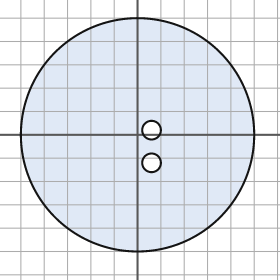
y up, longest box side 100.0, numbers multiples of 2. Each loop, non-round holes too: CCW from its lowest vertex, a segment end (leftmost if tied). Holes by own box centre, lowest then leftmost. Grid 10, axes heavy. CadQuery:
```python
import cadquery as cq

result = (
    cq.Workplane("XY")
    .moveTo(0.0, 0.0)
    .circle(50.0)
    .moveTo(6.0, -12.0)
    .circle(4.0)
    .moveTo(6.0, 2.0)
    .circle(4.0)
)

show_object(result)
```